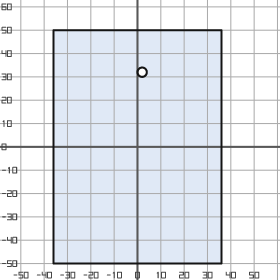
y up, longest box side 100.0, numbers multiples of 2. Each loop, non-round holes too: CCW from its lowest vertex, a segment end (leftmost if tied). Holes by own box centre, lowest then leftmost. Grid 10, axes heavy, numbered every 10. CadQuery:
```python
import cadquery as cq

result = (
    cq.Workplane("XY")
    .moveTo(-36.0, -50.0)
    .lineTo(36.0, -50.0)
    .lineTo(36.0, 50.0)
    .lineTo(-36.0, 50.0)
    .close()
    .moveTo(2.0, 32.0)
    .circle(2.0)
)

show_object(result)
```